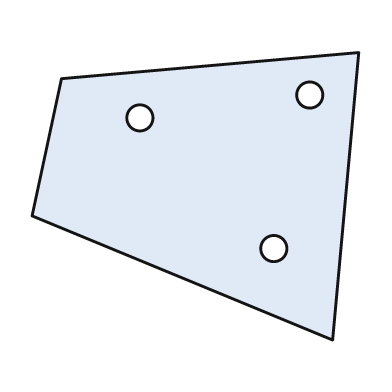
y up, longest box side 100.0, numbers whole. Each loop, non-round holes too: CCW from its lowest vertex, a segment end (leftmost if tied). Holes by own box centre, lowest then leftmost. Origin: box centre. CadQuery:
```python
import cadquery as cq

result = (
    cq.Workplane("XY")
    .moveTo(42.0, -44.0)
    .lineTo(50.0, 44.0)
    .lineTo(-41.0, 36.0)
    .lineTo(-50.0, -6.0)
    .close()
    .moveTo(24.0, -16.0)
    .circle(4.0)
    .moveTo(-17.0, 24.0)
    .circle(4.0)
    .moveTo(35.0, 31.0)
    .circle(4.0)
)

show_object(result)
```